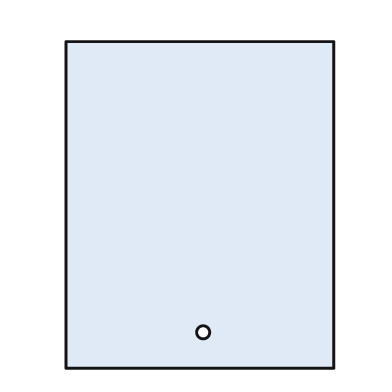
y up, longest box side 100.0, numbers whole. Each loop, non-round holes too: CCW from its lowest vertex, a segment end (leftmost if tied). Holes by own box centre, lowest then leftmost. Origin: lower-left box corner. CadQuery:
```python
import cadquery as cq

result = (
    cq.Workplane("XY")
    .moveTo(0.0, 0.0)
    .lineTo(82.0, 0.0)
    .lineTo(82.0, 100.0)
    .lineTo(0.0, 100.0)
    .close()
    .moveTo(42.0, 11.0)
    .circle(2.0)
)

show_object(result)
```